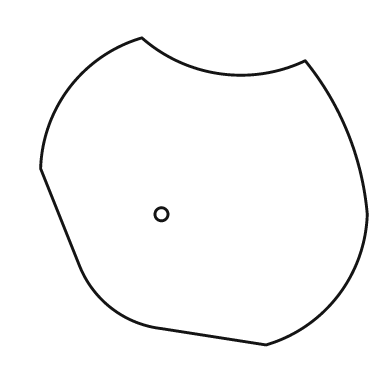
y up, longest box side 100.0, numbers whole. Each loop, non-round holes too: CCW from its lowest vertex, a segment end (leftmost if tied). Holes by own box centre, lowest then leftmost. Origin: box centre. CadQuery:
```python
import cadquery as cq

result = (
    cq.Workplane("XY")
    .moveTo(19.0, -47.0)
    .threePointArc((41.0, -32.0), (50.0, -7.0))
    .threePointArc((44.0, 18.0), (31.0, 40.0))
    .threePointArc((5.0, 36.0), (-19.0, 47.0))
    .threePointArc((-41.0, 32.0), (-50.0, 7.0))
    .lineTo(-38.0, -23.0)
    .threePointArc((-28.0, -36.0), (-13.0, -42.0))
    .close()
    .moveTo(-13.0, -7.0)
    .circle(2.0)
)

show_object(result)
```